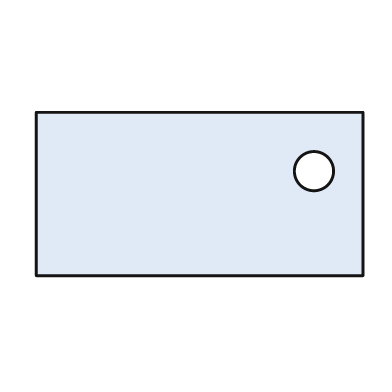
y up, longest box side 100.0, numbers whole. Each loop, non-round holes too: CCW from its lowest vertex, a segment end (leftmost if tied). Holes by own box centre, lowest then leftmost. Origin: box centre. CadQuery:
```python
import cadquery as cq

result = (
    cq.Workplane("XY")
    .moveTo(-50.0, -25.0)
    .lineTo(50.0, -25.0)
    .lineTo(50.0, 25.0)
    .lineTo(-50.0, 25.0)
    .close()
    .moveTo(35.0, 7.0)
    .circle(6.0)
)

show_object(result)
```